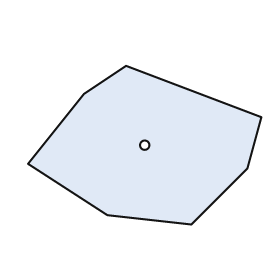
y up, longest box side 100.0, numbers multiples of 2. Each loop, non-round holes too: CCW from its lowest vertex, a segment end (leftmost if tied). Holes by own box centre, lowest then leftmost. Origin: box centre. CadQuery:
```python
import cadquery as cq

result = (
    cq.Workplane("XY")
    .moveTo(20.0, -34.0)
    .lineTo(44.0, -10.0)
    .lineTo(50.0, 12.0)
    .lineTo(-8.0, 34.0)
    .lineTo(-26.0, 22.0)
    .lineTo(-50.0, -8.0)
    .lineTo(-16.0, -30.0)
    .close()
    .moveTo(0.0, 0.0)
    .circle(2.0)
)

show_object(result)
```